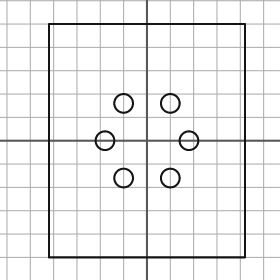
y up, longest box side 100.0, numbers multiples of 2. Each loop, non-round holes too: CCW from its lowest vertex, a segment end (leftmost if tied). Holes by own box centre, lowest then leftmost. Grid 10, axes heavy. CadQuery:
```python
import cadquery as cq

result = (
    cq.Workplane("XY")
    .moveTo(-42.0, -50.0)
    .lineTo(42.0, -50.0)
    .lineTo(42.0, 50.0)
    .lineTo(-42.0, 50.0)
    .close()
    .moveTo(-10.0, -16.0)
    .circle(4.0)
    .moveTo(10.0, -16.0)
    .circle(4.0)
    .moveTo(-18.0, 0.0)
    .circle(4.0)
    .moveTo(18.0, 0.0)
    .circle(4.0)
    .moveTo(-10.0, 16.0)
    .circle(4.0)
    .moveTo(10.0, 16.0)
    .circle(4.0)
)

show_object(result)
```